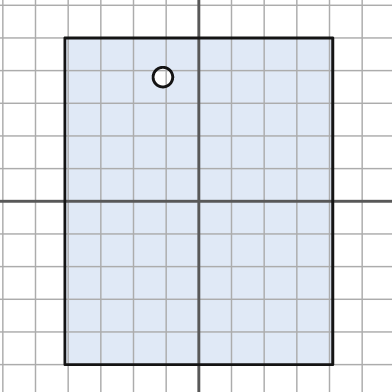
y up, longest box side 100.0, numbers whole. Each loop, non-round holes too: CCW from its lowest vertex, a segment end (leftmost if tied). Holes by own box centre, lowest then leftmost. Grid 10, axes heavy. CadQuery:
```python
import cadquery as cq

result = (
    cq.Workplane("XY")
    .moveTo(-41.0, -50.0)
    .lineTo(41.0, -50.0)
    .lineTo(41.0, 50.0)
    .lineTo(-41.0, 50.0)
    .close()
    .moveTo(-11.0, 38.0)
    .circle(3.0)
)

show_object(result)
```